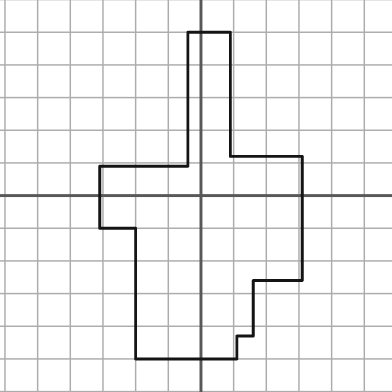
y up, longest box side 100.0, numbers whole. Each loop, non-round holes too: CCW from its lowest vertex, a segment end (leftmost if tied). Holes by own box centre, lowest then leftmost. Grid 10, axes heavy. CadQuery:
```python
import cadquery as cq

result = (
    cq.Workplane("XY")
    .moveTo(-20.0, -50.0)
    .lineTo(11.0, -50.0)
    .lineTo(11.0, -43.0)
    .lineTo(16.0, -43.0)
    .lineTo(16.0, -26.0)
    .lineTo(31.0, -26.0)
    .lineTo(31.0, 12.0)
    .lineTo(9.0, 12.0)
    .lineTo(9.0, 50.0)
    .lineTo(-4.0, 50.0)
    .lineTo(-4.0, 9.0)
    .lineTo(-31.0, 9.0)
    .lineTo(-31.0, -10.0)
    .lineTo(-20.0, -10.0)
    .close()
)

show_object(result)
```